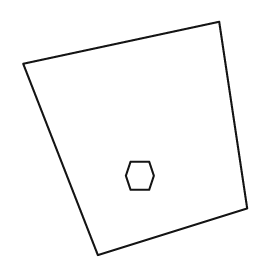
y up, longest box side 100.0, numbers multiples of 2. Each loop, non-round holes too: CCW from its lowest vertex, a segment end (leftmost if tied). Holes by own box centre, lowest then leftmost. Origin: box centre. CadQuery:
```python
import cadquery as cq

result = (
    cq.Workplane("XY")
    .moveTo(-16.0, -50.0)
    .lineTo(48.0, -30.0)
    .lineTo(36.0, 50.0)
    .lineTo(-48.0, 32.0)
    .close()
    .moveTo(-2.0, -22.0)
    .lineTo(6.0, -22.0)
    .lineTo(8.0, -16.0)
    .lineTo(6.0, -10.0)
    .lineTo(-2.0, -10.0)
    .lineTo(-4.0, -16.0)
    .close()
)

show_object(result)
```